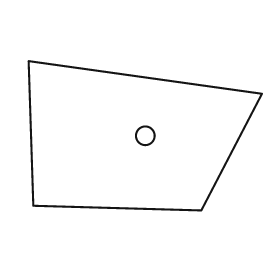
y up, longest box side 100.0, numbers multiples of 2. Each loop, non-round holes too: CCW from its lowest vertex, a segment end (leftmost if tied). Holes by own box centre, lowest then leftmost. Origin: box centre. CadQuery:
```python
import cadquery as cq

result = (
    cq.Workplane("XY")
    .moveTo(24.0, -32.0)
    .lineTo(50.0, 18.0)
    .lineTo(-50.0, 32.0)
    .lineTo(-48.0, -30.0)
    .close()
    .moveTo(0.0, 0.0)
    .circle(4.0)
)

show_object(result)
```